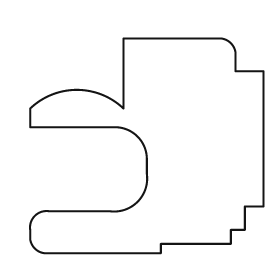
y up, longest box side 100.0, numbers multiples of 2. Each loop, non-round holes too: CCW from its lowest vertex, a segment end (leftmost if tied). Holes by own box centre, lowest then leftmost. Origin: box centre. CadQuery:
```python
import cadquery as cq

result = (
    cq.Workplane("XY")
    .moveTo(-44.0, -46.0)
    .lineTo(6.0, -46.0)
    .lineTo(6.0, -42.0)
    .lineTo(36.0, -42.0)
    .lineTo(36.0, -36.0)
    .lineTo(42.0, -36.0)
    .lineTo(42.0, -26.0)
    .lineTo(50.0, -26.0)
    .lineTo(50.0, 32.0)
    .lineTo(38.0, 32.0)
    .lineTo(38.0, 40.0)
    .threePointArc((36.0, 44.0), (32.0, 46.0))
    .lineTo(-10.0, 46.0)
    .lineTo(-10.0, 16.0)
    .threePointArc((-30.0, 24.0), (-50.0, 16.0))
    .lineTo(-50.0, 8.0)
    .lineTo(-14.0, 8.0)
    .threePointArc((-4.0, 4.0), (0.0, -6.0))
    .lineTo(0.0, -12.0)
    .threePointArc((-4.0, -24.0), (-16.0, -28.0))
    .lineTo(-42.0, -28.0)
    .threePointArc((-48.0, -30.0), (-50.0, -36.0))
    .lineTo(-50.0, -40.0)
    .threePointArc((-48.0, -44.0), (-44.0, -46.0))
    .close()
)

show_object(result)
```